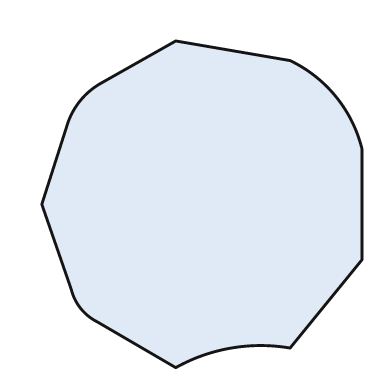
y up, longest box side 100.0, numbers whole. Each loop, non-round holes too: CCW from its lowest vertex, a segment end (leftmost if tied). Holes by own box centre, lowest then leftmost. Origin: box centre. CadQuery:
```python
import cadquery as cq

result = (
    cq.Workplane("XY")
    .moveTo(-8.0, -50.0)
    .threePointArc((9.0, -44.0), (27.0, -44.0))
    .lineTo(49.0, -17.0)
    .lineTo(49.0, 17.0)
    .threePointArc((41.0, 33.0), (27.0, 44.0))
    .lineTo(-8.0, 50.0)
    .lineTo(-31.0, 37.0)
    .threePointArc((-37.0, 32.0), (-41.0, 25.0))
    .lineTo(-49.0, 0.0)
    .lineTo(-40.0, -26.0)
    .threePointArc((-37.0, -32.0), (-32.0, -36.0))
    .close()
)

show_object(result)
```